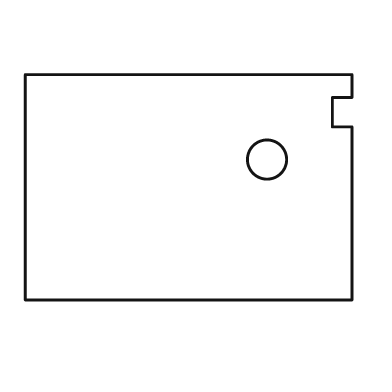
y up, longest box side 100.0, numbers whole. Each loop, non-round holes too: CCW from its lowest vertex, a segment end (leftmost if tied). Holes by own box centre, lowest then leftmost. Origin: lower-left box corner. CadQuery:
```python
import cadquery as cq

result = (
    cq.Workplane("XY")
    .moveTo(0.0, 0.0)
    .lineTo(100.0, 0.0)
    .lineTo(100.0, 53.0)
    .lineTo(94.0, 53.0)
    .lineTo(94.0, 62.0)
    .lineTo(100.0, 62.0)
    .lineTo(100.0, 69.0)
    .lineTo(0.0, 69.0)
    .close()
    .moveTo(74.0, 43.0)
    .circle(6.0)
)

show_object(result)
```